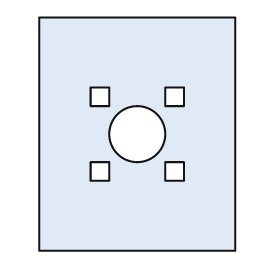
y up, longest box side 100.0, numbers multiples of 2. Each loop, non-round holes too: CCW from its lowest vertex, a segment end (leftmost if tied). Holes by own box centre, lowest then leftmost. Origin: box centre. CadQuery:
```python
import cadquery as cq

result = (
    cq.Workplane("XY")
    .moveTo(-42.0, -50.0)
    .lineTo(42.0, -50.0)
    .lineTo(42.0, 50.0)
    .lineTo(-42.0, 50.0)
    .close()
    .moveTo(-20.0, -20.0)
    .lineTo(-12.0, -20.0)
    .lineTo(-12.0, -12.0)
    .lineTo(-20.0, -12.0)
    .close()
    .moveTo(12.0, -20.0)
    .lineTo(20.0, -20.0)
    .lineTo(20.0, -12.0)
    .lineTo(12.0, -12.0)
    .close()
    .moveTo(0.0, 0.0)
    .circle(12.0)
    .moveTo(-20.0, 12.0)
    .lineTo(-12.0, 12.0)
    .lineTo(-12.0, 20.0)
    .lineTo(-20.0, 20.0)
    .close()
    .moveTo(12.0, 12.0)
    .lineTo(20.0, 12.0)
    .lineTo(20.0, 20.0)
    .lineTo(12.0, 20.0)
    .close()
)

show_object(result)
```